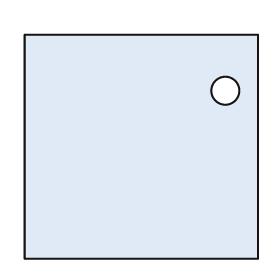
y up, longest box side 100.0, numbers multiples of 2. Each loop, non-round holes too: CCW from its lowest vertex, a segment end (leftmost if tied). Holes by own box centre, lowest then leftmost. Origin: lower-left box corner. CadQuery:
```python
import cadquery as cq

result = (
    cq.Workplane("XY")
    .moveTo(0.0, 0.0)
    .lineTo(100.0, 0.0)
    .lineTo(100.0, 96.0)
    .lineTo(0.0, 96.0)
    .close()
    .moveTo(86.0, 72.0)
    .circle(6.0)
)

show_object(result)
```